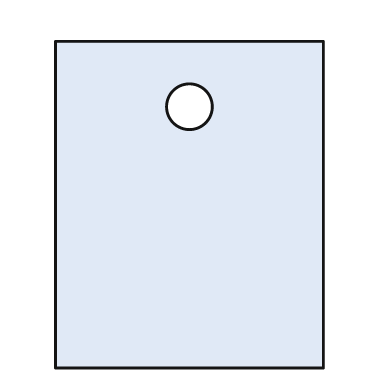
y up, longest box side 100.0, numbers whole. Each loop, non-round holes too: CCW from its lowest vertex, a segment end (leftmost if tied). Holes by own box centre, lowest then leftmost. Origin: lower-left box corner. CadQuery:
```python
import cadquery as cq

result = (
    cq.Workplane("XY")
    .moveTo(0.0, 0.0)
    .lineTo(82.0, 0.0)
    .lineTo(82.0, 100.0)
    .lineTo(0.0, 100.0)
    .close()
    .moveTo(41.0, 80.0)
    .circle(7.0)
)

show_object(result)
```